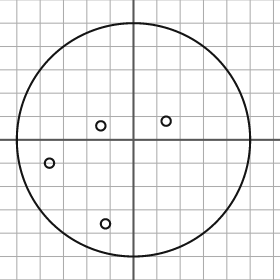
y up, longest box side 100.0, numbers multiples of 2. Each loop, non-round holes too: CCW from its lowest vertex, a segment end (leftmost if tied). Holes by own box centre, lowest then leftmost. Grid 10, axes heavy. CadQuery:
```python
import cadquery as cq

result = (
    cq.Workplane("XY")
    .moveTo(0.0, 0.0)
    .circle(50.0)
    .moveTo(-12.0, -36.0)
    .circle(2.0)
    .moveTo(-36.0, -10.0)
    .circle(2.0)
    .moveTo(-14.0, 6.0)
    .circle(2.0)
    .moveTo(14.0, 8.0)
    .circle(2.0)
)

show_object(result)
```